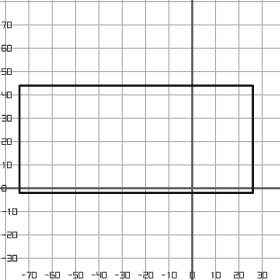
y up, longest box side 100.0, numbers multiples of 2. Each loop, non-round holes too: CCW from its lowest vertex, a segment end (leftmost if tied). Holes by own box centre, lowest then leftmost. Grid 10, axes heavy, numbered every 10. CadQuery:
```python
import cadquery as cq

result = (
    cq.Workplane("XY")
    .moveTo(-74.0, -2.0)
    .lineTo(26.0, -2.0)
    .lineTo(26.0, 44.0)
    .lineTo(-74.0, 44.0)
    .close()
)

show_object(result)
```